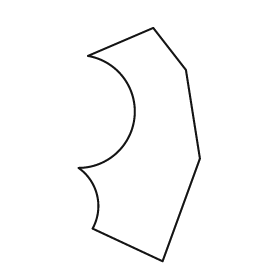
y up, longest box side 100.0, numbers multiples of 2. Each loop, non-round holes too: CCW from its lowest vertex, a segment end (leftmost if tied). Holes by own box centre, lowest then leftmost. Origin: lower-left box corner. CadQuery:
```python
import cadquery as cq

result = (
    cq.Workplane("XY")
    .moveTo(36.0, 0.0)
    .lineTo(52.0, 44.0)
    .lineTo(46.0, 82.0)
    .lineTo(32.0, 100.0)
    .lineTo(4.0, 88.0)
    .threePointArc((24.0, 62.0), (0.0, 40.0))
    .threePointArc((8.0, 28.0), (6.0, 14.0))
    .close()
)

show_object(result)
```